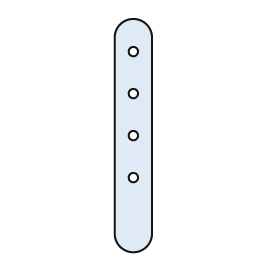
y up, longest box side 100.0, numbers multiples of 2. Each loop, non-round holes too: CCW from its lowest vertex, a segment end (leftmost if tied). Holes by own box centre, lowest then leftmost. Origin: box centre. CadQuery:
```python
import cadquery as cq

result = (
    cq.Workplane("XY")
    .moveTo(-8.0, -42.0)
    .threePointArc((0.0, -50.0), (8.0, -42.0))
    .lineTo(8.0, 42.0)
    .threePointArc((0.0, 50.0), (-8.0, 42.0))
    .close()
    .moveTo(0.0, -18.0)
    .circle(2.0)
    .moveTo(0.0, 0.0)
    .circle(2.0)
    .moveTo(0.0, 18.0)
    .circle(2.0)
    .moveTo(0.0, 36.0)
    .circle(2.0)
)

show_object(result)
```